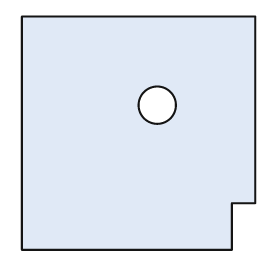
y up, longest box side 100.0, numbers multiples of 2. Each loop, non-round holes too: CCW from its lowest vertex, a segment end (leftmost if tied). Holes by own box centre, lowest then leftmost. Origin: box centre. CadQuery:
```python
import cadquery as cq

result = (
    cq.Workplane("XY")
    .moveTo(-50.0, -50.0)
    .lineTo(40.0, -50.0)
    .lineTo(40.0, -30.0)
    .lineTo(50.0, -30.0)
    .lineTo(50.0, 50.0)
    .lineTo(-50.0, 50.0)
    .close()
    .moveTo(8.0, 12.0)
    .circle(8.0)
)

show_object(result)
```